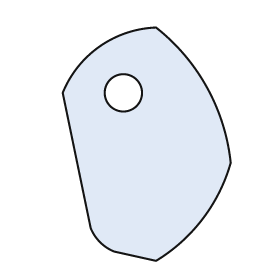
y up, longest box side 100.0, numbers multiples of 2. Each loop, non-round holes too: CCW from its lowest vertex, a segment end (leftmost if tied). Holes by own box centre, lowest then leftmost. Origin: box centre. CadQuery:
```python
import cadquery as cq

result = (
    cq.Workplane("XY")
    .moveTo(4.0, -50.0)
    .threePointArc((24.0, -32.0), (36.0, -8.0))
    .threePointArc((26.0, 24.0), (4.0, 50.0))
    .threePointArc((-20.0, 42.0), (-36.0, 22.0))
    .lineTo(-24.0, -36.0)
    .threePointArc((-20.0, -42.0), (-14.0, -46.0))
    .close()
    .moveTo(-10.0, 22.0)
    .circle(8.0)
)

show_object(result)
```